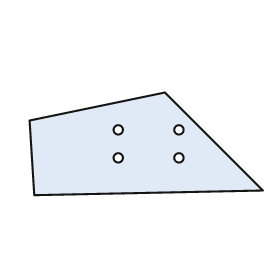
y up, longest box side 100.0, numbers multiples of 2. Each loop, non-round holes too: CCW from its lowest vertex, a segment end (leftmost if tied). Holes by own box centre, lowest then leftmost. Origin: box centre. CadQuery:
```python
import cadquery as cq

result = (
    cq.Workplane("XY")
    .moveTo(-48.0, -22.0)
    .lineTo(50.0, -20.0)
    .lineTo(8.0, 22.0)
    .lineTo(-50.0, 10.0)
    .close()
    .moveTo(-12.0, -6.0)
    .circle(2.0)
    .moveTo(14.0, -6.0)
    .circle(2.0)
    .moveTo(-12.0, 6.0)
    .circle(2.0)
    .moveTo(14.0, 6.0)
    .circle(2.0)
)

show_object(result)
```